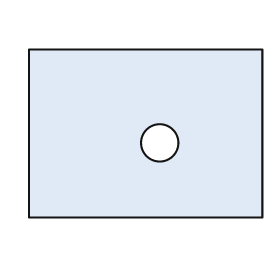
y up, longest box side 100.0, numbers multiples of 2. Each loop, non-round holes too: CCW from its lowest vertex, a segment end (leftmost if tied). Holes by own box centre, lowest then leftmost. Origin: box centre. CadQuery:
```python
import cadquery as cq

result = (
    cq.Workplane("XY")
    .moveTo(-50.0, -36.0)
    .lineTo(50.0, -36.0)
    .lineTo(50.0, 36.0)
    .lineTo(-50.0, 36.0)
    .close()
    .moveTo(6.0, -4.0)
    .circle(8.0)
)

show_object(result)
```